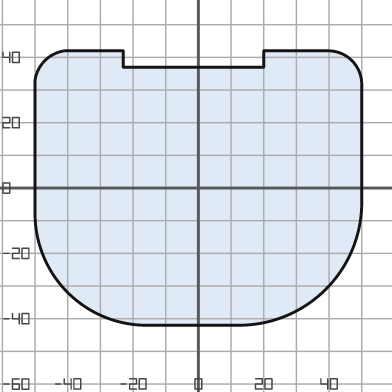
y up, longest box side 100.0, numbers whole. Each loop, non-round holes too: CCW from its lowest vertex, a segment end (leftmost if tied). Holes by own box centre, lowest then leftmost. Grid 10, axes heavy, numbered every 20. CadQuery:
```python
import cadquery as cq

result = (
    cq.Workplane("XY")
    .moveTo(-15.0, -42.0)
    .lineTo(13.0, -42.0)
    .threePointArc((39.0, -31.0), (50.0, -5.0))
    .lineTo(50.0, 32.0)
    .threePointArc((47.0, 39.0), (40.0, 42.0))
    .lineTo(20.0, 42.0)
    .lineTo(20.0, 37.0)
    .lineTo(-23.0, 37.0)
    .lineTo(-23.0, 42.0)
    .lineTo(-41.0, 42.0)
    .threePointArc((-47.0, 39.0), (-50.0, 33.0))
    .lineTo(-50.0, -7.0)
    .threePointArc((-40.0, -32.0), (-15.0, -42.0))
    .close()
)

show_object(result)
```